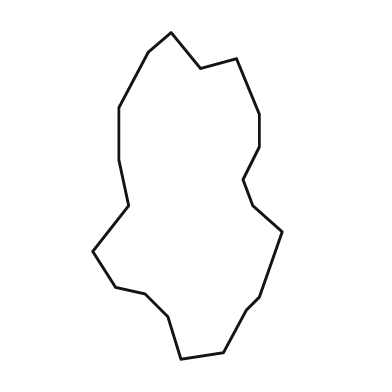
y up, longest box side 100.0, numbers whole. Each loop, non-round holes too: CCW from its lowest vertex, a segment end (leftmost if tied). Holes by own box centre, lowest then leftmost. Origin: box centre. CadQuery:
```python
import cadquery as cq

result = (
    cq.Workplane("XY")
    .moveTo(-2.0, -50.0)
    .lineTo(11.0, -48.0)
    .lineTo(18.0, -35.0)
    .lineTo(22.0, -31.0)
    .lineTo(29.0, -11.0)
    .lineTo(20.0, -3.0)
    .lineTo(17.0, 5.0)
    .lineTo(22.0, 15.0)
    .lineTo(22.0, 25.0)
    .lineTo(15.0, 42.0)
    .lineTo(4.0, 39.0)
    .lineTo(-5.0, 50.0)
    .lineTo(-12.0, 44.0)
    .lineTo(-21.0, 27.0)
    .lineTo(-21.0, 11.0)
    .lineTo(-18.0, -3.0)
    .lineTo(-29.0, -17.0)
    .lineTo(-22.0, -28.0)
    .lineTo(-13.0, -30.0)
    .lineTo(-6.0, -37.0)
    .close()
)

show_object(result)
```